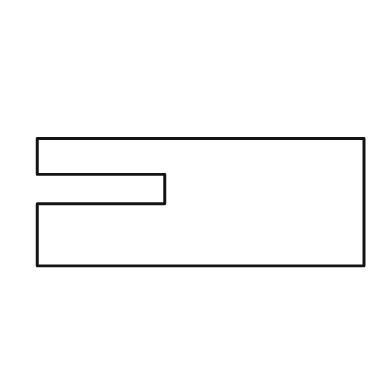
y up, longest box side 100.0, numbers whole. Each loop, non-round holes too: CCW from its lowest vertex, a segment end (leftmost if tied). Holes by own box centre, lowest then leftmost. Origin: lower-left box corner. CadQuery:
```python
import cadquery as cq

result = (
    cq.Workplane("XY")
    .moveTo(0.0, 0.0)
    .lineTo(100.0, 0.0)
    .lineTo(100.0, 39.0)
    .lineTo(0.0, 39.0)
    .lineTo(0.0, 28.0)
    .lineTo(39.0, 28.0)
    .lineTo(39.0, 19.0)
    .lineTo(0.0, 19.0)
    .close()
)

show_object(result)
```